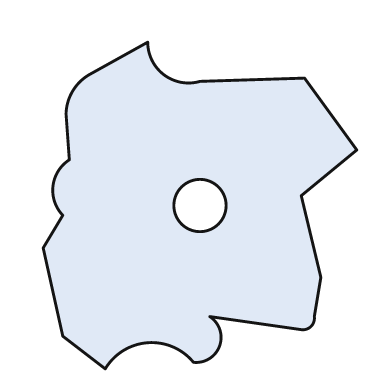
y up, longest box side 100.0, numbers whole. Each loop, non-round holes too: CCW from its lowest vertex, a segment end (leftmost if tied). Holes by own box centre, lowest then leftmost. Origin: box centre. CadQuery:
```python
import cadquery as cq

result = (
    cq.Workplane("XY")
    .moveTo(-29.0, -50.0)
    .threePointArc((-16.0, -42.0), (-2.0, -48.0))
    .threePointArc((6.0, -43.0), (3.0, -34.0))
    .lineTo(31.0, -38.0)
    .threePointArc((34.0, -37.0), (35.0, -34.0))
    .lineTo(37.0, -22.0)
    .lineTo(31.0, 3.0)
    .lineTo(48.0, 17.0)
    .lineTo(32.0, 39.0)
    .lineTo(0.0, 38.0)
    .threePointArc((-11.0, 40.0), (-16.0, 50.0))
    .lineTo(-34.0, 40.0)
    .threePointArc((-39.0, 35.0), (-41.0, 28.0))
    .lineTo(-40.0, 14.0)
    .threePointArc((-45.0, 6.0), (-42.0, -3.0))
    .lineTo(-48.0, -13.0)
    .lineTo(-42.0, -40.0)
    .close()
    .moveTo(0.0, 0.0)
    .circle(8.0)
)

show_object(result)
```